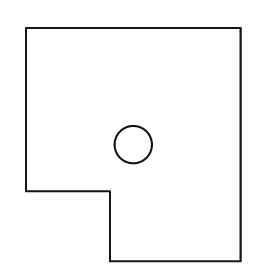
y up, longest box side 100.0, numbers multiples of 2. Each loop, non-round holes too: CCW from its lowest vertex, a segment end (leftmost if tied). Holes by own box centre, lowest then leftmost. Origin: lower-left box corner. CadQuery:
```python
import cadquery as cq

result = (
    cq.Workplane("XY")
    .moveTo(36.0, 0.0)
    .lineTo(92.0, 0.0)
    .lineTo(92.0, 100.0)
    .lineTo(0.0, 100.0)
    .lineTo(0.0, 30.0)
    .lineTo(36.0, 30.0)
    .close()
    .moveTo(46.0, 50.0)
    .circle(8.0)
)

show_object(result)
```